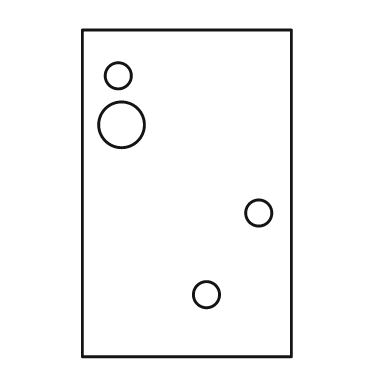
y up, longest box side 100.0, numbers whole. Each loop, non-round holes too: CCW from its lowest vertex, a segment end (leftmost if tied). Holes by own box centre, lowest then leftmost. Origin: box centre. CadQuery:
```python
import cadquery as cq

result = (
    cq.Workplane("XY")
    .moveTo(-32.0, -50.0)
    .lineTo(32.0, -50.0)
    .lineTo(32.0, 50.0)
    .lineTo(-32.0, 50.0)
    .close()
    .moveTo(6.0, -31.0)
    .circle(4.0)
    .moveTo(22.0, -6.0)
    .circle(4.0)
    .moveTo(-20.0, 21.0)
    .circle(7.0)
    .moveTo(-21.0, 36.0)
    .circle(4.0)
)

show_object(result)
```